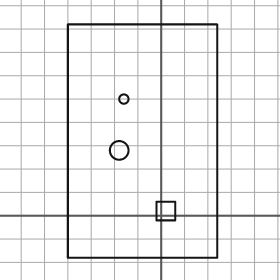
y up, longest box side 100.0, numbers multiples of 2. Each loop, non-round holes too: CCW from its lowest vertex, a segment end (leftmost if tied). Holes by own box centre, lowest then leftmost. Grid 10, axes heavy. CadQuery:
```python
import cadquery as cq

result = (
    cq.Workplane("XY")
    .moveTo(-40.0, -18.0)
    .lineTo(24.0, -18.0)
    .lineTo(24.0, 82.0)
    .lineTo(-40.0, 82.0)
    .close()
    .moveTo(-2.0, -2.0)
    .lineTo(6.0, -2.0)
    .lineTo(6.0, 6.0)
    .lineTo(-2.0, 6.0)
    .close()
    .moveTo(-18.0, 28.0)
    .circle(4.0)
    .moveTo(-16.0, 50.0)
    .circle(2.0)
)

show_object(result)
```